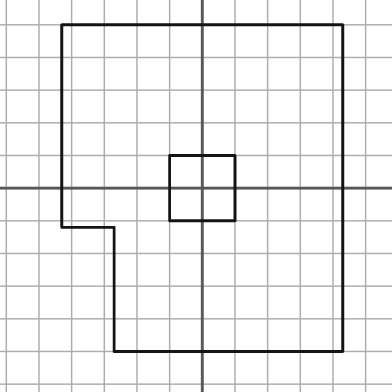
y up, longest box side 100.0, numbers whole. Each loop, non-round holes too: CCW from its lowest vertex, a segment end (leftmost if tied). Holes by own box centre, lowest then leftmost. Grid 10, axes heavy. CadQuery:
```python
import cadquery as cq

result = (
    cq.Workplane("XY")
    .moveTo(-27.0, -50.0)
    .lineTo(43.0, -50.0)
    .lineTo(43.0, 50.0)
    .lineTo(-43.0, 50.0)
    .lineTo(-43.0, -12.0)
    .lineTo(-27.0, -12.0)
    .close()
    .moveTo(-10.0, -10.0)
    .lineTo(10.0, -10.0)
    .lineTo(10.0, 10.0)
    .lineTo(-10.0, 10.0)
    .close()
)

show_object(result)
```